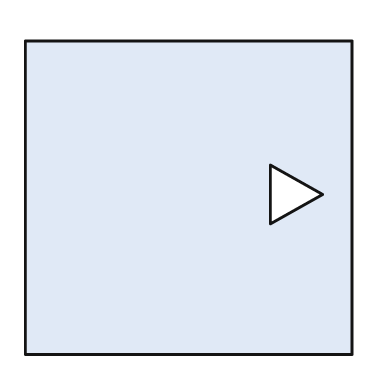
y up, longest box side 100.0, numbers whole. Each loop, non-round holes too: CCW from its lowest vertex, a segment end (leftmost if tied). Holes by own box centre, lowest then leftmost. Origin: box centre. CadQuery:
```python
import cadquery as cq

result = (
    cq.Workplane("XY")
    .moveTo(-50.0, -48.0)
    .lineTo(50.0, -48.0)
    .lineTo(50.0, 48.0)
    .lineTo(-50.0, 48.0)
    .close()
    .moveTo(25.0, -8.0)
    .lineTo(41.0, 1.0)
    .lineTo(25.0, 10.0)
    .close()
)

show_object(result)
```